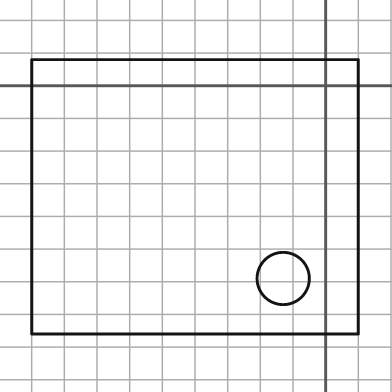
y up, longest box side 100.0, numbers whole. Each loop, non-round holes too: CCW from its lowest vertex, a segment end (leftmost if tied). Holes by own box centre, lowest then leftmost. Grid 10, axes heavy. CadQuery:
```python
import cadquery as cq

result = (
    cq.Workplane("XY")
    .moveTo(-90.0, -76.0)
    .lineTo(10.0, -76.0)
    .lineTo(10.0, 8.0)
    .lineTo(-90.0, 8.0)
    .close()
    .moveTo(-13.0, -59.0)
    .circle(8.0)
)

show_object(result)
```